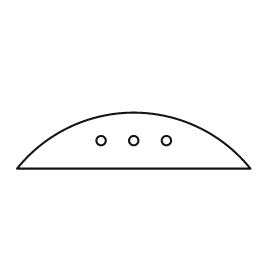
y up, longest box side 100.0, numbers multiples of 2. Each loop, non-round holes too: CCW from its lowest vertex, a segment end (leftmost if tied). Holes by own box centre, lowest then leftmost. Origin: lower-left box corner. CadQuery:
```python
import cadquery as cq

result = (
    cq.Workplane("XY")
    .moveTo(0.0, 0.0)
    .lineTo(100.0, 0.0)
    .threePointArc((50.0, 24.0), (0.0, 0.0))
    .close()
    .moveTo(36.0, 12.0)
    .circle(2.0)
    .moveTo(50.0, 12.0)
    .circle(2.0)
    .moveTo(64.0, 12.0)
    .circle(2.0)
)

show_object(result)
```